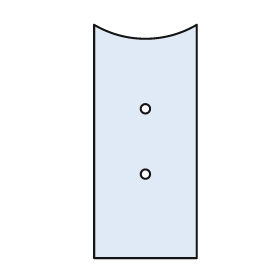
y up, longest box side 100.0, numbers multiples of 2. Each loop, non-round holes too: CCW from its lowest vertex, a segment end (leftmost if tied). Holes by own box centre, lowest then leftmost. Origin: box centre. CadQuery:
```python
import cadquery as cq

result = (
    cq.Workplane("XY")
    .moveTo(-22.0, -50.0)
    .lineTo(22.0, -50.0)
    .lineTo(22.0, 50.0)
    .threePointArc((0.0, 44.0), (-22.0, 50.0))
    .close()
    .moveTo(0.0, -14.0)
    .circle(2.0)
    .moveTo(0.0, 14.0)
    .circle(2.0)
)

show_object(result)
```